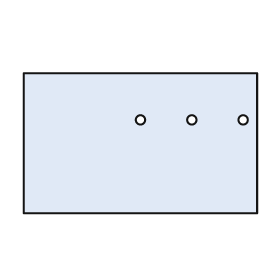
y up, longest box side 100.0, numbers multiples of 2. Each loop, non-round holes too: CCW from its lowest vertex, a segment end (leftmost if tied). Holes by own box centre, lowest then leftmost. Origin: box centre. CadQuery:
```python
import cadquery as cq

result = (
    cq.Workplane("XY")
    .moveTo(-50.0, -30.0)
    .lineTo(50.0, -30.0)
    .lineTo(50.0, 30.0)
    .lineTo(-50.0, 30.0)
    .close()
    .moveTo(0.0, 10.0)
    .circle(2.0)
    .moveTo(22.0, 10.0)
    .circle(2.0)
    .moveTo(44.0, 10.0)
    .circle(2.0)
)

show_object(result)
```